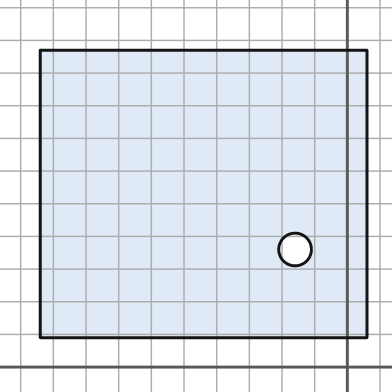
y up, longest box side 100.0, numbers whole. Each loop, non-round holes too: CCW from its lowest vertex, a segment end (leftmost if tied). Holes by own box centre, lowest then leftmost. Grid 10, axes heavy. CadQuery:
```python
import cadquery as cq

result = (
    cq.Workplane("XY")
    .moveTo(-94.0, 9.0)
    .lineTo(6.0, 9.0)
    .lineTo(6.0, 97.0)
    .lineTo(-94.0, 97.0)
    .close()
    .moveTo(-16.0, 36.0)
    .circle(5.0)
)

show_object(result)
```